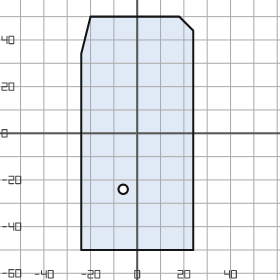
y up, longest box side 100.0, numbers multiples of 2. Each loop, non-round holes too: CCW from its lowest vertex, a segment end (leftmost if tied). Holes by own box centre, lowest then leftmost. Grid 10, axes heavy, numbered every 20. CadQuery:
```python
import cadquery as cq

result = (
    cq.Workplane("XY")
    .moveTo(-24.0, -50.0)
    .lineTo(24.0, -50.0)
    .lineTo(24.0, 44.0)
    .lineTo(18.0, 50.0)
    .lineTo(-20.0, 50.0)
    .lineTo(-24.0, 34.0)
    .close()
    .moveTo(-6.0, -24.0)
    .circle(2.0)
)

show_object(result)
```